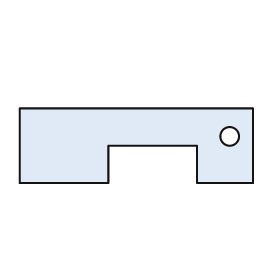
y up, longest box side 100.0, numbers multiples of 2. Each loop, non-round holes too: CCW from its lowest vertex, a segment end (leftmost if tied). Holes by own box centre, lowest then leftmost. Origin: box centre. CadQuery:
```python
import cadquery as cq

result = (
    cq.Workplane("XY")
    .moveTo(-50.0, -16.0)
    .lineTo(-12.0, -16.0)
    .lineTo(-12.0, 0.0)
    .lineTo(26.0, 0.0)
    .lineTo(26.0, -16.0)
    .lineTo(50.0, -16.0)
    .lineTo(50.0, 16.0)
    .lineTo(-50.0, 16.0)
    .close()
    .moveTo(40.0, 4.0)
    .circle(4.0)
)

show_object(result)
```